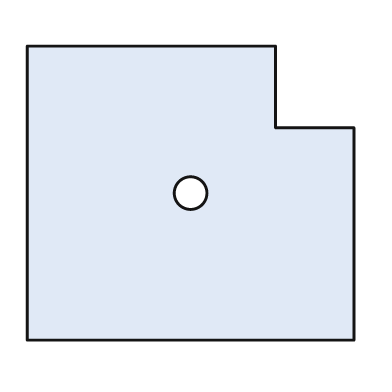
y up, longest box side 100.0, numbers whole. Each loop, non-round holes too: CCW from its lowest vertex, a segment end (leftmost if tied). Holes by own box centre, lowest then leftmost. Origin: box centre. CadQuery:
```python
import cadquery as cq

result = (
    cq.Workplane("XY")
    .moveTo(-50.0, -45.0)
    .lineTo(50.0, -45.0)
    .lineTo(50.0, 20.0)
    .lineTo(26.0, 20.0)
    .lineTo(26.0, 45.0)
    .lineTo(-50.0, 45.0)
    .close()
    .moveTo(0.0, 0.0)
    .circle(5.0)
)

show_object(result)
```